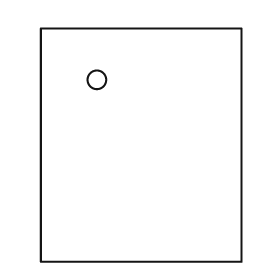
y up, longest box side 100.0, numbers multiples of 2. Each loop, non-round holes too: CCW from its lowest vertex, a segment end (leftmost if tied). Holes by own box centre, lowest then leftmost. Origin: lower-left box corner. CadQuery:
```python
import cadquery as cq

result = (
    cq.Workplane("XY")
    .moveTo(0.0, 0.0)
    .lineTo(86.0, 0.0)
    .lineTo(86.0, 100.0)
    .lineTo(0.0, 100.0)
    .close()
    .moveTo(24.0, 78.0)
    .circle(4.0)
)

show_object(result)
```